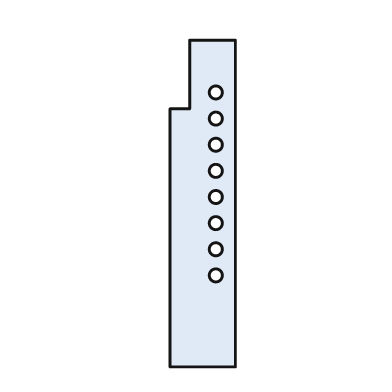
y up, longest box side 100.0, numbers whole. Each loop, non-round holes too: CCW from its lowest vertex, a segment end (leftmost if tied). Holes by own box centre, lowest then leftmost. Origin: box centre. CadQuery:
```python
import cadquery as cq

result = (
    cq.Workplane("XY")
    .moveTo(-10.0, -50.0)
    .lineTo(10.0, -50.0)
    .lineTo(10.0, 50.0)
    .lineTo(-4.0, 50.0)
    .lineTo(-4.0, 29.0)
    .lineTo(-10.0, 29.0)
    .close()
    .moveTo(4.0, -22.0)
    .circle(2.0)
    .moveTo(4.0, -14.0)
    .circle(2.0)
    .moveTo(4.0, -6.0)
    .circle(2.0)
    .moveTo(4.0, 2.0)
    .circle(2.0)
    .moveTo(4.0, 10.0)
    .circle(2.0)
    .moveTo(4.0, 18.0)
    .circle(2.0)
    .moveTo(4.0, 26.0)
    .circle(2.0)
    .moveTo(4.0, 34.0)
    .circle(2.0)
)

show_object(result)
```